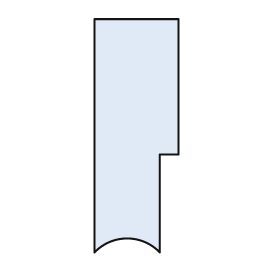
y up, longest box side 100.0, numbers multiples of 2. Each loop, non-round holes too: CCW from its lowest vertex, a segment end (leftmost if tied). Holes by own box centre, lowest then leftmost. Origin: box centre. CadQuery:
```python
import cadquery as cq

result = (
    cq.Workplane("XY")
    .moveTo(-18.0, -50.0)
    .threePointArc((-4.0, -44.0), (10.0, -50.0))
    .lineTo(10.0, -8.0)
    .lineTo(18.0, -8.0)
    .lineTo(18.0, 50.0)
    .lineTo(-18.0, 50.0)
    .close()
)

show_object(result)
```